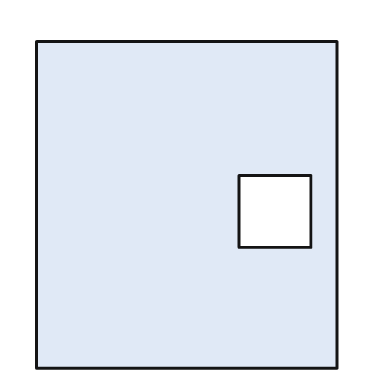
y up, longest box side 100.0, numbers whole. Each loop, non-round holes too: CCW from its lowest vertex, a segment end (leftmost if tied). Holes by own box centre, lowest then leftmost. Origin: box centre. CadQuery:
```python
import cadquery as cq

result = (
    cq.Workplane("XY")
    .moveTo(-46.0, -50.0)
    .lineTo(46.0, -50.0)
    .lineTo(46.0, 50.0)
    .lineTo(-46.0, 50.0)
    .close()
    .moveTo(16.0, -13.0)
    .lineTo(38.0, -13.0)
    .lineTo(38.0, 9.0)
    .lineTo(16.0, 9.0)
    .close()
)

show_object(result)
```